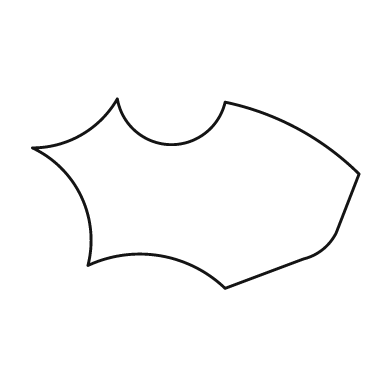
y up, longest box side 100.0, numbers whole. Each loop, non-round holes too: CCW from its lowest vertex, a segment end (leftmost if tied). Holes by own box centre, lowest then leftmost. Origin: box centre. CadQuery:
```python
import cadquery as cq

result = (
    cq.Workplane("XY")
    .moveTo(9.0, -29.0)
    .lineTo(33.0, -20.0)
    .threePointArc((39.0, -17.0), (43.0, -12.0))
    .lineTo(50.0, 6.0)
    .threePointArc((31.0, 20.0), (9.0, 28.0))
    .threePointArc((-8.0, 15.0), (-24.0, 29.0))
    .threePointArc((-35.0, 18.0), (-50.0, 14.0))
    .threePointArc((-35.0, -1.0), (-33.0, -22.0))
    .threePointArc((-11.0, -19.0), (9.0, -29.0))
    .close()
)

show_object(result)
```